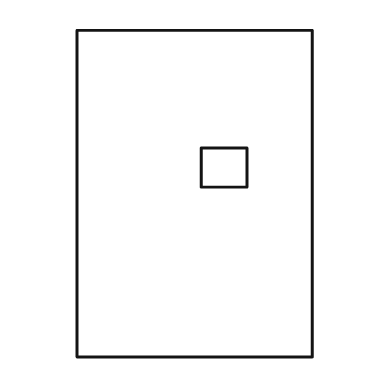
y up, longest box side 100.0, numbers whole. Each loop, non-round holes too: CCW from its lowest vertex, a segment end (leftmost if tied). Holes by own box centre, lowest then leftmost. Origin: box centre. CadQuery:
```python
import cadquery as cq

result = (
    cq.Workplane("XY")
    .moveTo(-36.0, -50.0)
    .lineTo(36.0, -50.0)
    .lineTo(36.0, 50.0)
    .lineTo(-36.0, 50.0)
    .close()
    .moveTo(2.0, 2.0)
    .lineTo(16.0, 2.0)
    .lineTo(16.0, 14.0)
    .lineTo(2.0, 14.0)
    .close()
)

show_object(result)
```